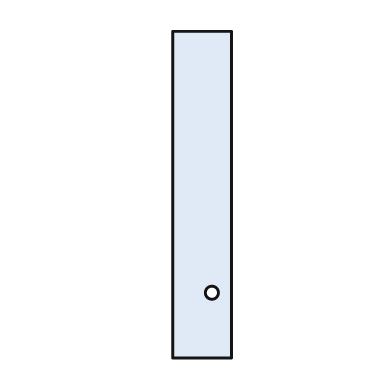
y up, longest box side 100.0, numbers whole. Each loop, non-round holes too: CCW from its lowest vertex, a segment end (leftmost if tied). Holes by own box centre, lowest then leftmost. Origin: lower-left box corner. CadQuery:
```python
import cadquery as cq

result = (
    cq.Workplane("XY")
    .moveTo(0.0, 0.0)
    .lineTo(18.0, 0.0)
    .lineTo(18.0, 100.0)
    .lineTo(0.0, 100.0)
    .close()
    .moveTo(12.0, 20.0)
    .circle(2.0)
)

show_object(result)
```